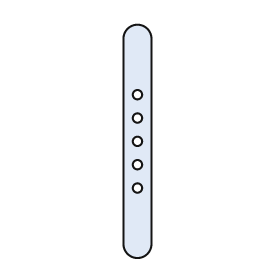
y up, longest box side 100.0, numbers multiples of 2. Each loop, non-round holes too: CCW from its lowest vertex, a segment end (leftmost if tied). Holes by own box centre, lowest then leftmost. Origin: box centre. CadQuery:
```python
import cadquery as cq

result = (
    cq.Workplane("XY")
    .moveTo(-6.0, -44.0)
    .threePointArc((0.0, -50.0), (6.0, -44.0))
    .lineTo(6.0, 44.0)
    .threePointArc((0.0, 50.0), (-6.0, 44.0))
    .close()
    .moveTo(0.0, -20.0)
    .circle(2.0)
    .moveTo(0.0, -10.0)
    .circle(2.0)
    .moveTo(0.0, 0.0)
    .circle(2.0)
    .moveTo(0.0, 10.0)
    .circle(2.0)
    .moveTo(0.0, 20.0)
    .circle(2.0)
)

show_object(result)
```